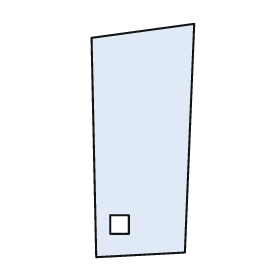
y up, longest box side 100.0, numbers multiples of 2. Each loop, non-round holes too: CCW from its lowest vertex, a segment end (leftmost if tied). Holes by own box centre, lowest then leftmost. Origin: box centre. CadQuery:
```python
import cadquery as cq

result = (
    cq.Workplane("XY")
    .moveTo(-20.0, -50.0)
    .lineTo(18.0, -48.0)
    .lineTo(22.0, 50.0)
    .lineTo(-22.0, 44.0)
    .close()
    .moveTo(-14.0, -40.0)
    .lineTo(-6.0, -40.0)
    .lineTo(-6.0, -32.0)
    .lineTo(-14.0, -32.0)
    .close()
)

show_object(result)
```